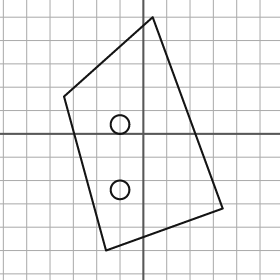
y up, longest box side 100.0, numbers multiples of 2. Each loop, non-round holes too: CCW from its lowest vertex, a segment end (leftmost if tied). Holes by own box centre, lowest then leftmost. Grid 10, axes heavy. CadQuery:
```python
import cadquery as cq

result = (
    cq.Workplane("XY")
    .moveTo(-16.0, -50.0)
    .lineTo(34.0, -32.0)
    .lineTo(4.0, 50.0)
    .lineTo(-34.0, 16.0)
    .close()
    .moveTo(-10.0, -24.0)
    .circle(4.0)
    .moveTo(-10.0, 4.0)
    .circle(4.0)
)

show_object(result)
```